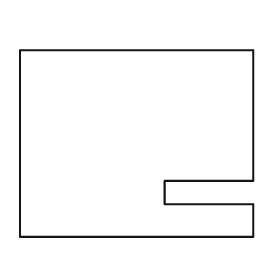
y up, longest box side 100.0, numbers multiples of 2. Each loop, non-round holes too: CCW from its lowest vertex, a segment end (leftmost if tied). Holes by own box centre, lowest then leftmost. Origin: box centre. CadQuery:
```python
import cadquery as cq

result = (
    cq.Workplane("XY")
    .moveTo(-50.0, -40.0)
    .lineTo(50.0, -40.0)
    .lineTo(50.0, -26.0)
    .lineTo(12.0, -26.0)
    .lineTo(12.0, -16.0)
    .lineTo(50.0, -16.0)
    .lineTo(50.0, 40.0)
    .lineTo(-50.0, 40.0)
    .close()
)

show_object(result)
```